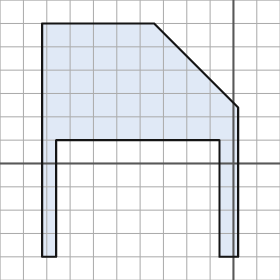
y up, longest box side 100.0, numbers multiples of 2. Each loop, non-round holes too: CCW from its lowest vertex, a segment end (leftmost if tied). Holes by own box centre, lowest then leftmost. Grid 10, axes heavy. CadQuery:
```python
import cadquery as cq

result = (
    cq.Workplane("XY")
    .moveTo(-82.0, -40.0)
    .lineTo(-76.0, -40.0)
    .lineTo(-76.0, 10.0)
    .lineTo(-6.0, 10.0)
    .lineTo(-6.0, -40.0)
    .lineTo(2.0, -40.0)
    .lineTo(2.0, 24.0)
    .lineTo(-34.0, 60.0)
    .lineTo(-82.0, 60.0)
    .close()
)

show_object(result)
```